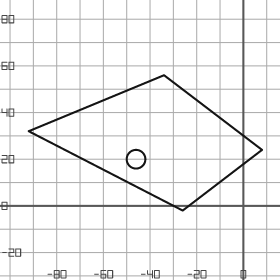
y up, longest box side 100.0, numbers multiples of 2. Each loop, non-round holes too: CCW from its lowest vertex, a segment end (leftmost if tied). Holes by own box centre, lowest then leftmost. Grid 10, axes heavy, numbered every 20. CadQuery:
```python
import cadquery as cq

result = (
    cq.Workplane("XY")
    .moveTo(-26.0, -2.0)
    .lineTo(8.0, 24.0)
    .lineTo(-34.0, 56.0)
    .lineTo(-92.0, 32.0)
    .close()
    .moveTo(-46.0, 20.0)
    .circle(4.0)
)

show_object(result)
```